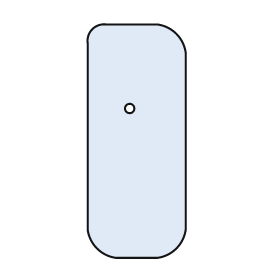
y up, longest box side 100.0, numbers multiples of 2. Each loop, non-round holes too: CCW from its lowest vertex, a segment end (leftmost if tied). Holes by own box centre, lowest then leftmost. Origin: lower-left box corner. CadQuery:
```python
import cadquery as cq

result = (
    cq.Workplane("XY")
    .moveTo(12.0, 0.0)
    .lineTo(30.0, 0.0)
    .threePointArc((38.0, 4.0), (42.0, 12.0))
    .lineTo(42.0, 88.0)
    .threePointArc((38.0, 96.0), (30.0, 100.0))
    .lineTo(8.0, 100.0)
    .threePointArc((2.0, 98.0), (0.0, 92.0))
    .lineTo(0.0, 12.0)
    .threePointArc((4.0, 4.0), (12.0, 0.0))
    .close()
    .moveTo(18.0, 64.0)
    .circle(2.0)
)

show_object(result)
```